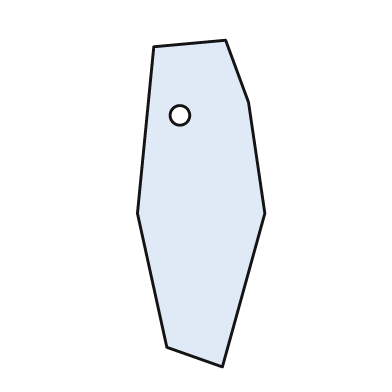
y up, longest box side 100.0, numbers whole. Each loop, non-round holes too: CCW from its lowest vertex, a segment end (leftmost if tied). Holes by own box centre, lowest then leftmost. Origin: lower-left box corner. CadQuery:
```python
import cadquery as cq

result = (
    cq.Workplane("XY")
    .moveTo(26.0, 0.0)
    .lineTo(39.0, 47.0)
    .lineTo(34.0, 81.0)
    .lineTo(27.0, 100.0)
    .lineTo(5.0, 98.0)
    .lineTo(0.0, 47.0)
    .lineTo(9.0, 6.0)
    .close()
    .moveTo(13.0, 77.0)
    .circle(3.0)
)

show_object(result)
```